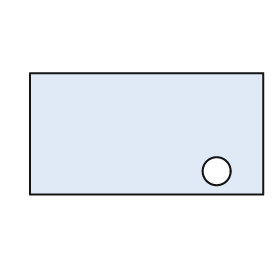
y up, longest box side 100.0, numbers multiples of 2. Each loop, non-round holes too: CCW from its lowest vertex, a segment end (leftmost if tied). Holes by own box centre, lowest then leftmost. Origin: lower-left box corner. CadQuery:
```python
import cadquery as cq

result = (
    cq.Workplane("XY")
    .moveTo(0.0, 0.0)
    .lineTo(100.0, 0.0)
    .lineTo(100.0, 52.0)
    .lineTo(0.0, 52.0)
    .close()
    .moveTo(80.0, 10.0)
    .circle(6.0)
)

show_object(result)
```